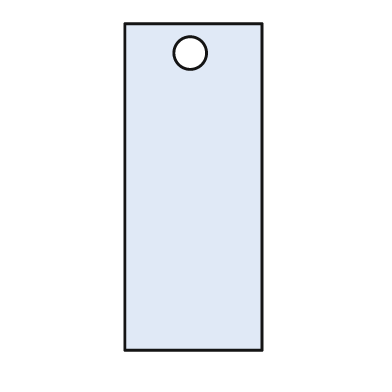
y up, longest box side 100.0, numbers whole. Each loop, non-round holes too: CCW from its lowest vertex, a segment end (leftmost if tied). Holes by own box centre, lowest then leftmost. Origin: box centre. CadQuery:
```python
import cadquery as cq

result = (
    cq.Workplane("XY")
    .moveTo(-21.0, -50.0)
    .lineTo(21.0, -50.0)
    .lineTo(21.0, 50.0)
    .lineTo(-21.0, 50.0)
    .close()
    .moveTo(-1.0, 41.0)
    .circle(5.0)
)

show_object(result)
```